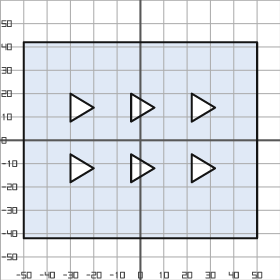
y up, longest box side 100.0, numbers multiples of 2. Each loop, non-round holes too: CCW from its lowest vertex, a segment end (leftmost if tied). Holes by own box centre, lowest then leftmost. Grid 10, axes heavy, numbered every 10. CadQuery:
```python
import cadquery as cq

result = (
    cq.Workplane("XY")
    .moveTo(-50.0, -42.0)
    .lineTo(50.0, -42.0)
    .lineTo(50.0, 42.0)
    .lineTo(-50.0, 42.0)
    .close()
    .moveTo(-30.0, -18.0)
    .lineTo(-20.0, -12.0)
    .lineTo(-30.0, -6.0)
    .close()
    .moveTo(-4.0, -18.0)
    .lineTo(6.0, -12.0)
    .lineTo(-4.0, -6.0)
    .close()
    .moveTo(22.0, -18.0)
    .lineTo(32.0, -12.0)
    .lineTo(22.0, -6.0)
    .close()
    .moveTo(-30.0, 8.0)
    .lineTo(-20.0, 14.0)
    .lineTo(-30.0, 20.0)
    .close()
    .moveTo(-4.0, 8.0)
    .lineTo(6.0, 14.0)
    .lineTo(-4.0, 20.0)
    .close()
    .moveTo(22.0, 8.0)
    .lineTo(32.0, 14.0)
    .lineTo(22.0, 20.0)
    .close()
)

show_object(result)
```